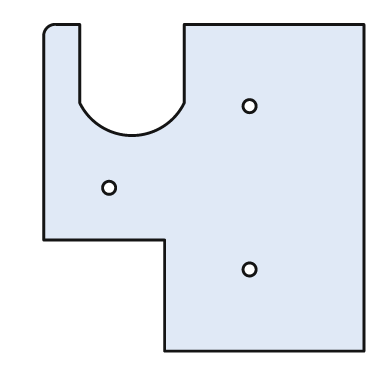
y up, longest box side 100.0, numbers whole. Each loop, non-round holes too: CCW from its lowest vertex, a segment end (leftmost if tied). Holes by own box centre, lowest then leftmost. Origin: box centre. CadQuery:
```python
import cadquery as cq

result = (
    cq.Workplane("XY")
    .moveTo(-12.0, -50.0)
    .lineTo(49.0, -50.0)
    .lineTo(49.0, 50.0)
    .lineTo(-6.0, 50.0)
    .lineTo(-6.0, 26.0)
    .threePointArc((-22.0, 16.0), (-38.0, 26.0))
    .lineTo(-38.0, 50.0)
    .lineTo(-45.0, 50.0)
    .threePointArc((-48.0, 49.0), (-49.0, 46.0))
    .lineTo(-49.0, -16.0)
    .lineTo(-12.0, -16.0)
    .close()
    .moveTo(14.0, -25.0)
    .circle(2.0)
    .moveTo(-29.0, 0.0)
    .circle(2.0)
    .moveTo(14.0, 25.0)
    .circle(2.0)
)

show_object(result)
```